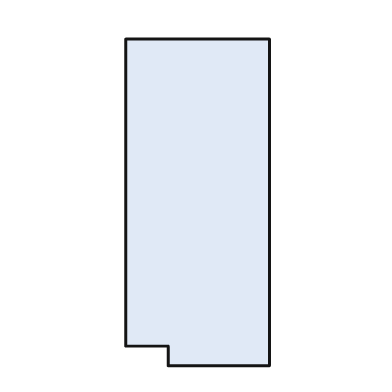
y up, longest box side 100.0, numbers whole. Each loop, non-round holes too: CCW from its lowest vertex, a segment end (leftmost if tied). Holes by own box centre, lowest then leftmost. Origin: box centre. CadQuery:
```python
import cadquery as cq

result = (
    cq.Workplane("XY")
    .moveTo(-9.0, -50.0)
    .lineTo(22.0, -50.0)
    .lineTo(22.0, 50.0)
    .lineTo(-22.0, 50.0)
    .lineTo(-22.0, -44.0)
    .lineTo(-9.0, -44.0)
    .close()
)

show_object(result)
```